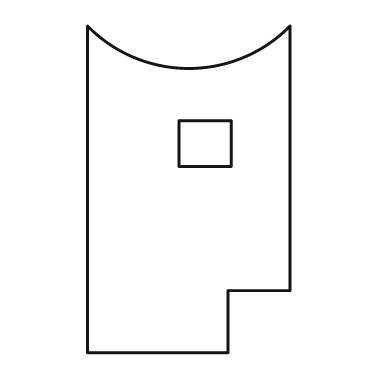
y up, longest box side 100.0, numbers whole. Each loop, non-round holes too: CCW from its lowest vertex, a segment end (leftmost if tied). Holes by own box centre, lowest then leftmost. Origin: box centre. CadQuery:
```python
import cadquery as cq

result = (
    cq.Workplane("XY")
    .moveTo(-31.0, -50.0)
    .lineTo(12.0, -50.0)
    .lineTo(12.0, -31.0)
    .lineTo(31.0, -31.0)
    .lineTo(31.0, 50.0)
    .threePointArc((0.0, 37.0), (-31.0, 50.0))
    .close()
    .moveTo(-3.0, 7.0)
    .lineTo(13.0, 7.0)
    .lineTo(13.0, 21.0)
    .lineTo(-3.0, 21.0)
    .close()
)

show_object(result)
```